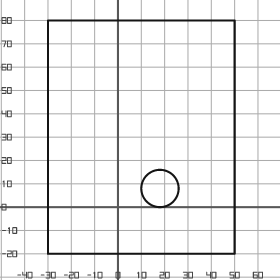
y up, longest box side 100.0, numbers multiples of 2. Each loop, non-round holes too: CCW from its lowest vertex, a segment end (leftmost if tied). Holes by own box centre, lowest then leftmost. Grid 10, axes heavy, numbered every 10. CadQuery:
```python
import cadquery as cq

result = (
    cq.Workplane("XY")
    .moveTo(-30.0, -20.0)
    .lineTo(50.0, -20.0)
    .lineTo(50.0, 80.0)
    .lineTo(-30.0, 80.0)
    .close()
    .moveTo(18.0, 8.0)
    .circle(8.0)
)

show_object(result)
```